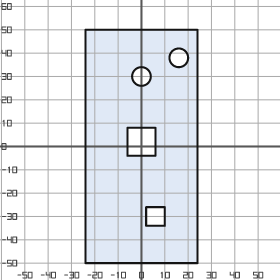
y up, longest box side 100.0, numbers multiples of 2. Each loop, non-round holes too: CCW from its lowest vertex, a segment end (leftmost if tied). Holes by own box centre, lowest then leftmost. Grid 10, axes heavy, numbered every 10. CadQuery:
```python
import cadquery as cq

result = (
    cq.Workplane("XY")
    .moveTo(-24.0, -50.0)
    .lineTo(24.0, -50.0)
    .lineTo(24.0, 50.0)
    .lineTo(-24.0, 50.0)
    .close()
    .moveTo(2.0, -34.0)
    .lineTo(10.0, -34.0)
    .lineTo(10.0, -26.0)
    .lineTo(2.0, -26.0)
    .close()
    .moveTo(-6.0, -4.0)
    .lineTo(6.0, -4.0)
    .lineTo(6.0, 8.0)
    .lineTo(-6.0, 8.0)
    .close()
    .moveTo(0.0, 30.0)
    .circle(4.0)
    .moveTo(16.0, 38.0)
    .circle(4.0)
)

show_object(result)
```